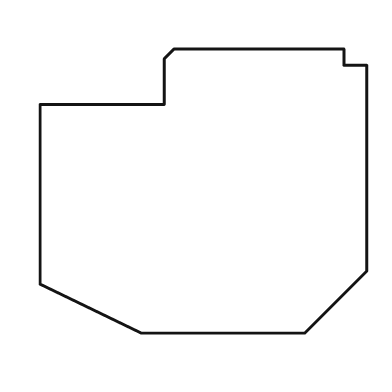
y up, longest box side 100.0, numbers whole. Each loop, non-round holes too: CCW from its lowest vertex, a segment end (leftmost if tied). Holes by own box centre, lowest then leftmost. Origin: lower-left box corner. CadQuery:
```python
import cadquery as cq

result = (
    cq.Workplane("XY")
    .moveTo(31.0, 0.0)
    .lineTo(81.0, 0.0)
    .lineTo(100.0, 19.0)
    .lineTo(100.0, 82.0)
    .lineTo(93.0, 82.0)
    .lineTo(93.0, 87.0)
    .lineTo(41.0, 87.0)
    .lineTo(38.0, 84.0)
    .lineTo(38.0, 70.0)
    .lineTo(0.0, 70.0)
    .lineTo(0.0, 15.0)
    .close()
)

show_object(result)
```